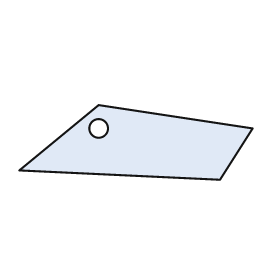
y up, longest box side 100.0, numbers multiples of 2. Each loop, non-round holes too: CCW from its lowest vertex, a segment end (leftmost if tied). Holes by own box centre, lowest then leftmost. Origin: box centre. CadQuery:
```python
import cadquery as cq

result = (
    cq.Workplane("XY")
    .moveTo(36.0, -16.0)
    .lineTo(50.0, 6.0)
    .lineTo(-16.0, 16.0)
    .lineTo(-50.0, -12.0)
    .close()
    .moveTo(-16.0, 6.0)
    .circle(4.0)
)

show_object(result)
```